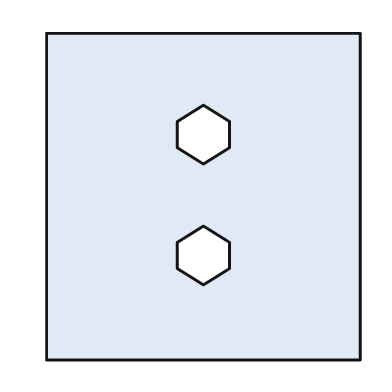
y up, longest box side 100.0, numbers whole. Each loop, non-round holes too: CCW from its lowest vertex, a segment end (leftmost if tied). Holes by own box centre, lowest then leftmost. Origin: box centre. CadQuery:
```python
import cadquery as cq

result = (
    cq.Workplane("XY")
    .moveTo(-48.0, -50.0)
    .lineTo(48.0, -50.0)
    .lineTo(48.0, 50.0)
    .lineTo(-48.0, 50.0)
    .close()
    .moveTo(0.0, -27.0)
    .lineTo(8.0, -22.0)
    .lineTo(8.0, -14.0)
    .lineTo(0.0, -9.0)
    .lineTo(-8.0, -14.0)
    .lineTo(-8.0, -22.0)
    .close()
    .moveTo(0.0, 10.0)
    .lineTo(8.0, 15.0)
    .lineTo(8.0, 23.0)
    .lineTo(0.0, 28.0)
    .lineTo(-8.0, 23.0)
    .lineTo(-8.0, 15.0)
    .close()
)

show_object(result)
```